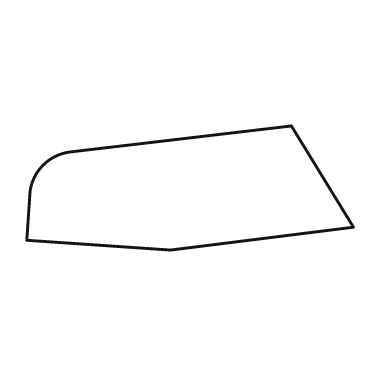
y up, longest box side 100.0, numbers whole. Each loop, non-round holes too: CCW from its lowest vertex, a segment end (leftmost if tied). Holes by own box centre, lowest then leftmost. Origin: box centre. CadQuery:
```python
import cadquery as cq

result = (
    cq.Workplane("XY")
    .moveTo(-6.0, -19.0)
    .lineTo(50.0, -12.0)
    .lineTo(31.0, 19.0)
    .lineTo(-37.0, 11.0)
    .threePointArc((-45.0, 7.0), (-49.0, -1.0))
    .lineTo(-50.0, -16.0)
    .close()
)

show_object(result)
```